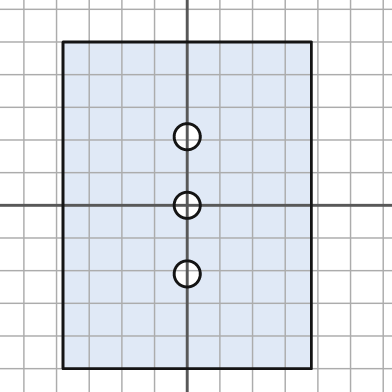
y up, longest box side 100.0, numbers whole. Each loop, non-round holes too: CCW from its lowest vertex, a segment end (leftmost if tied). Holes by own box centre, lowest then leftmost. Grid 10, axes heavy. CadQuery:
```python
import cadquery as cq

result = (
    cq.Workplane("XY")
    .moveTo(-38.0, -50.0)
    .lineTo(38.0, -50.0)
    .lineTo(38.0, 50.0)
    .lineTo(-38.0, 50.0)
    .close()
    .moveTo(0.0, -21.0)
    .circle(4.0)
    .moveTo(0.0, 0.0)
    .circle(4.0)
    .moveTo(0.0, 21.0)
    .circle(4.0)
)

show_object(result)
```